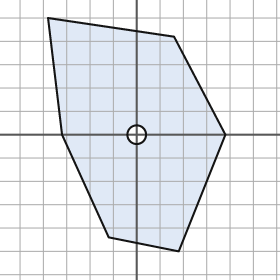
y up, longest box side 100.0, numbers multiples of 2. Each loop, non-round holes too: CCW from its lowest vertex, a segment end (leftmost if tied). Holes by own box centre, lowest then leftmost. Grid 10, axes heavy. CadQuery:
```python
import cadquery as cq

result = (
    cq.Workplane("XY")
    .moveTo(18.0, -50.0)
    .lineTo(38.0, 0.0)
    .lineTo(16.0, 42.0)
    .lineTo(-38.0, 50.0)
    .lineTo(-32.0, 0.0)
    .lineTo(-12.0, -44.0)
    .close()
    .moveTo(0.0, 0.0)
    .circle(4.0)
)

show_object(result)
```